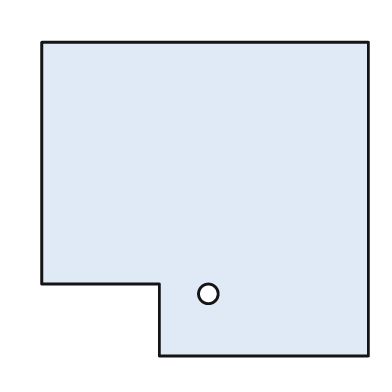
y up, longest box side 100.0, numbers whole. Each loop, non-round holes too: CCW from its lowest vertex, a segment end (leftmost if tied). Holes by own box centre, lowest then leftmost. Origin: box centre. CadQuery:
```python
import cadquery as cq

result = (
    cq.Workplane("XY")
    .moveTo(-14.0, -48.0)
    .lineTo(50.0, -48.0)
    .lineTo(50.0, 48.0)
    .lineTo(-50.0, 48.0)
    .lineTo(-50.0, -26.0)
    .lineTo(-14.0, -26.0)
    .close()
    .moveTo(1.0, -29.0)
    .circle(3.0)
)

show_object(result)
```